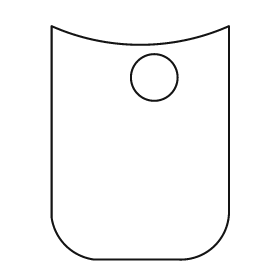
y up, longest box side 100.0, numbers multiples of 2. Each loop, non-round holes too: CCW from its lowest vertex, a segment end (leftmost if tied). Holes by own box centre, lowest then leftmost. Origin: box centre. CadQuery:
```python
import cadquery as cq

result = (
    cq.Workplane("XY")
    .moveTo(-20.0, -50.0)
    .lineTo(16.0, -50.0)
    .threePointArc((32.0, -44.0), (38.0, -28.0))
    .lineTo(38.0, 50.0)
    .threePointArc((0.0, 42.0), (-38.0, 50.0))
    .lineTo(-38.0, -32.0)
    .threePointArc((-32.0, -44.0), (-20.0, -50.0))
    .close()
    .moveTo(6.0, 28.0)
    .circle(10.0)
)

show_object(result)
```